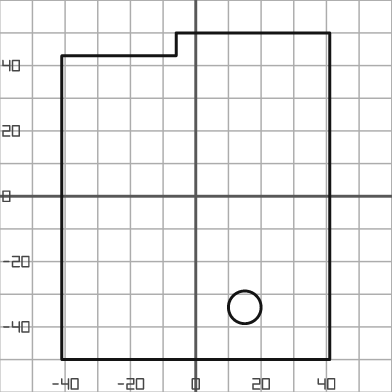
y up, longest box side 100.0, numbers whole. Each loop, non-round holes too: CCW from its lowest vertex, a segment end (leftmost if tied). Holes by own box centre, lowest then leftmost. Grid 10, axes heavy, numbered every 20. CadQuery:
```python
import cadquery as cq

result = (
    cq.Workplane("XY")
    .moveTo(-41.0, -50.0)
    .lineTo(41.0, -50.0)
    .lineTo(41.0, 50.0)
    .lineTo(-6.0, 50.0)
    .lineTo(-6.0, 43.0)
    .lineTo(-41.0, 43.0)
    .close()
    .moveTo(15.0, -34.0)
    .circle(5.0)
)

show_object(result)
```